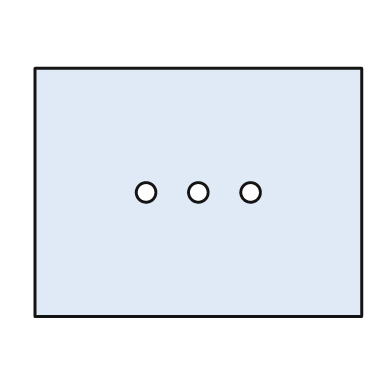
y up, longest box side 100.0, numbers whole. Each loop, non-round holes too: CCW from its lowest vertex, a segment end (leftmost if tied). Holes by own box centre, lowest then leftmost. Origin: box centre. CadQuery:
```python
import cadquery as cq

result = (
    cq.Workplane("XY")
    .moveTo(-50.0, -38.0)
    .lineTo(50.0, -38.0)
    .lineTo(50.0, 38.0)
    .lineTo(-50.0, 38.0)
    .close()
    .moveTo(-16.0, 0.0)
    .circle(3.0)
    .moveTo(0.0, 0.0)
    .circle(3.0)
    .moveTo(16.0, 0.0)
    .circle(3.0)
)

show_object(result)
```